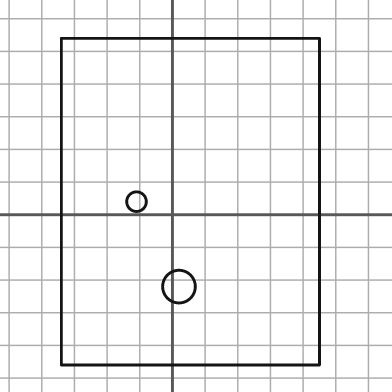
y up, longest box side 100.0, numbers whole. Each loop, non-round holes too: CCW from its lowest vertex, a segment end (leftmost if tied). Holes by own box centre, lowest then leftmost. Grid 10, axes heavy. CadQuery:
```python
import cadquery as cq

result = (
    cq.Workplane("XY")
    .moveTo(-34.0, -46.0)
    .lineTo(45.0, -46.0)
    .lineTo(45.0, 54.0)
    .lineTo(-34.0, 54.0)
    .close()
    .moveTo(2.0, -22.0)
    .circle(5.0)
    .moveTo(-11.0, 4.0)
    .circle(3.0)
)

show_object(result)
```